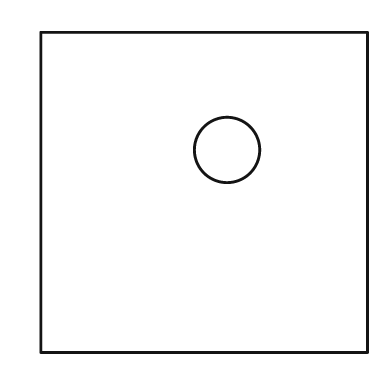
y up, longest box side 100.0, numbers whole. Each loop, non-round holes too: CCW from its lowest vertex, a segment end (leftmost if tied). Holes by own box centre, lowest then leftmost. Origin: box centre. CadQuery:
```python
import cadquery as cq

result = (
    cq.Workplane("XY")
    .moveTo(-50.0, -49.0)
    .lineTo(50.0, -49.0)
    .lineTo(50.0, 49.0)
    .lineTo(-50.0, 49.0)
    .close()
    .moveTo(7.0, 13.0)
    .circle(10.0)
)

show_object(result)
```